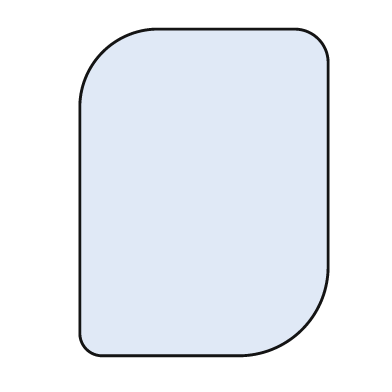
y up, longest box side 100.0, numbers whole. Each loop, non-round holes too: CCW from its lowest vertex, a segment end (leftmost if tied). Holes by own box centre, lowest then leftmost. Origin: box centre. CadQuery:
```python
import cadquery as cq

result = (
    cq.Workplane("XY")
    .moveTo(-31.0, -50.0)
    .lineTo(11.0, -50.0)
    .threePointArc((30.0, -42.0), (38.0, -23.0))
    .lineTo(38.0, 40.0)
    .threePointArc((35.0, 47.0), (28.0, 50.0))
    .lineTo(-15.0, 50.0)
    .threePointArc((-31.0, 43.0), (-38.0, 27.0))
    .lineTo(-38.0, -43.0)
    .threePointArc((-36.0, -48.0), (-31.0, -50.0))
    .close()
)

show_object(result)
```